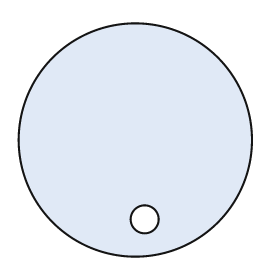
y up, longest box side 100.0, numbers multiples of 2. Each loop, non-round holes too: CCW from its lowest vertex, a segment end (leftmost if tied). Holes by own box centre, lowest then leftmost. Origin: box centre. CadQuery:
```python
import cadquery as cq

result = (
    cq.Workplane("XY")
    .moveTo(0.0, 0.0)
    .circle(50.0)
    .moveTo(4.0, -34.0)
    .circle(6.0)
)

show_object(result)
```